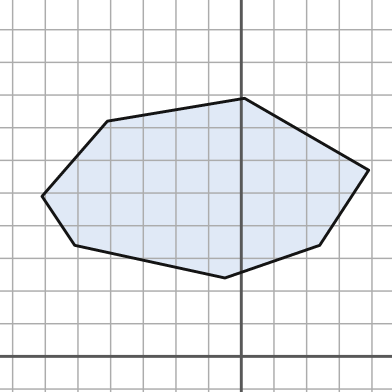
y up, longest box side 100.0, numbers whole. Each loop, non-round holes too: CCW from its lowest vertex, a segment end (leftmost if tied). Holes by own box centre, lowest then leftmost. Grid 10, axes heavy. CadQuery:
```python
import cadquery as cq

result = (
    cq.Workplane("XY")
    .moveTo(-5.0, 24.0)
    .lineTo(24.0, 34.0)
    .lineTo(39.0, 57.0)
    .lineTo(1.0, 79.0)
    .lineTo(-41.0, 72.0)
    .lineTo(-61.0, 49.0)
    .lineTo(-51.0, 34.0)
    .close()
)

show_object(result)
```